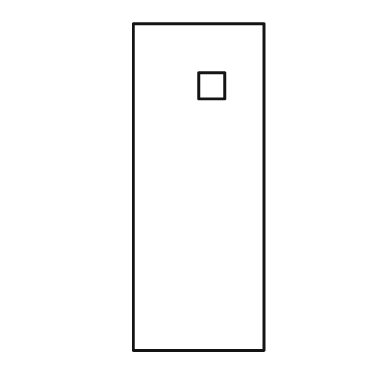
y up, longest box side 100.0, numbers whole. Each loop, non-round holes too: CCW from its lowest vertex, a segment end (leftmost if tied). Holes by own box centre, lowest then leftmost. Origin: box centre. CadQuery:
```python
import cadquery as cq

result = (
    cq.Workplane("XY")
    .moveTo(-20.0, -50.0)
    .lineTo(20.0, -50.0)
    .lineTo(20.0, 50.0)
    .lineTo(-20.0, 50.0)
    .close()
    .moveTo(0.0, 27.0)
    .lineTo(8.0, 27.0)
    .lineTo(8.0, 35.0)
    .lineTo(0.0, 35.0)
    .close()
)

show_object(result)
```